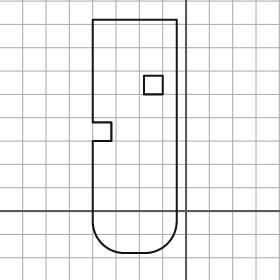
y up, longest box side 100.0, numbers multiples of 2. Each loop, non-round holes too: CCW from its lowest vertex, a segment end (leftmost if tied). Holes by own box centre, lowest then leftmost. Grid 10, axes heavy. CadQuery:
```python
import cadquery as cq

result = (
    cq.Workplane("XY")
    .moveTo(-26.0, -18.0)
    .lineTo(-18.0, -18.0)
    .threePointArc((-8.0, -14.0), (-4.0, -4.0))
    .lineTo(-4.0, 82.0)
    .lineTo(-40.0, 82.0)
    .lineTo(-40.0, 38.0)
    .lineTo(-32.0, 38.0)
    .lineTo(-32.0, 30.0)
    .lineTo(-40.0, 30.0)
    .lineTo(-40.0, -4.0)
    .threePointArc((-36.0, -14.0), (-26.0, -18.0))
    .close()
    .moveTo(-18.0, 50.0)
    .lineTo(-10.0, 50.0)
    .lineTo(-10.0, 58.0)
    .lineTo(-18.0, 58.0)
    .close()
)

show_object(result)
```